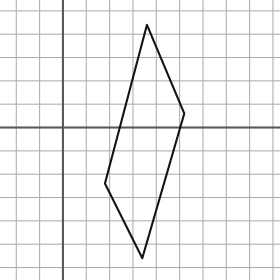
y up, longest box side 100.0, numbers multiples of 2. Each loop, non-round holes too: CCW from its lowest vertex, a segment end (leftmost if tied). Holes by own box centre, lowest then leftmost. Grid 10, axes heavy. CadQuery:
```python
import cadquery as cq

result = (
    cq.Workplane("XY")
    .moveTo(34.0, -56.0)
    .lineTo(52.0, 6.0)
    .lineTo(36.0, 44.0)
    .lineTo(18.0, -24.0)
    .close()
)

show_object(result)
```